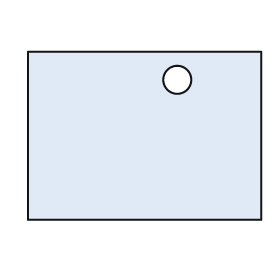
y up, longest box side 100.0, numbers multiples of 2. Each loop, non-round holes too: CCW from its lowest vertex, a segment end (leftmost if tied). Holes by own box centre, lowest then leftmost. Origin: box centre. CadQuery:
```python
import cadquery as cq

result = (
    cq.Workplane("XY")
    .moveTo(-50.0, -36.0)
    .lineTo(50.0, -36.0)
    .lineTo(50.0, 36.0)
    .lineTo(-50.0, 36.0)
    .close()
    .moveTo(14.0, 24.0)
    .circle(6.0)
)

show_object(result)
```